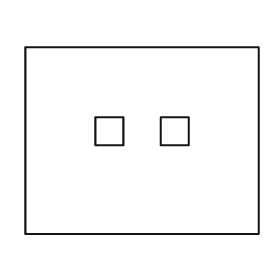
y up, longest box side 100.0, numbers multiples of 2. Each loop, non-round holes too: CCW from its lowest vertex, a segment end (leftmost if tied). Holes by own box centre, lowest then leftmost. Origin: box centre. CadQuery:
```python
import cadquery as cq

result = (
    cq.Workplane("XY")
    .moveTo(-50.0, -40.0)
    .lineTo(50.0, -40.0)
    .lineTo(50.0, 40.0)
    .lineTo(-50.0, 40.0)
    .close()
    .moveTo(-20.0, -2.0)
    .lineTo(-8.0, -2.0)
    .lineTo(-8.0, 10.0)
    .lineTo(-20.0, 10.0)
    .close()
    .moveTo(8.0, -2.0)
    .lineTo(20.0, -2.0)
    .lineTo(20.0, 10.0)
    .lineTo(8.0, 10.0)
    .close()
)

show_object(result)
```